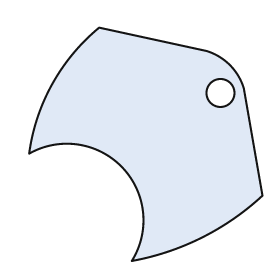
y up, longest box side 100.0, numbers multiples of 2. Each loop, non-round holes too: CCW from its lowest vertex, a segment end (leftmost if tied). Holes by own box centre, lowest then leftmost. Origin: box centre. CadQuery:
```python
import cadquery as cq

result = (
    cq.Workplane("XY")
    .moveTo(-6.0, -50.0)
    .threePointArc((24.0, -40.0), (50.0, -22.0))
    .lineTo(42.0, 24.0)
    .threePointArc((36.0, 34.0), (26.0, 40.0))
    .lineTo(-20.0, 50.0)
    .threePointArc((-40.0, 26.0), (-50.0, -4.0))
    .threePointArc((-10.0, -10.0), (-6.0, -50.0))
    .close()
    .moveTo(32.0, 22.0)
    .circle(6.0)
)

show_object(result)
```